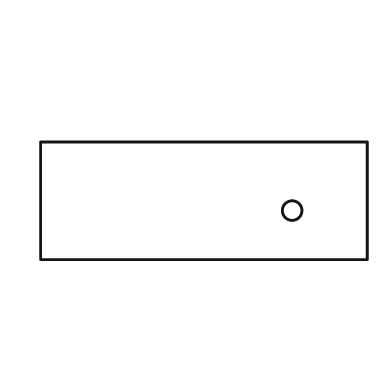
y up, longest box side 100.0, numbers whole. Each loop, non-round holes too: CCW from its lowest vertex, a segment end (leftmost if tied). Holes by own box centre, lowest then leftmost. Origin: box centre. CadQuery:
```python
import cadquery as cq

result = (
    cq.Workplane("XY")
    .moveTo(-50.0, -18.0)
    .lineTo(50.0, -18.0)
    .lineTo(50.0, 18.0)
    .lineTo(-50.0, 18.0)
    .close()
    .moveTo(27.0, -3.0)
    .circle(3.0)
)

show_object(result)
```